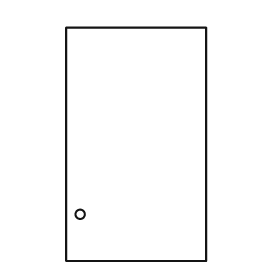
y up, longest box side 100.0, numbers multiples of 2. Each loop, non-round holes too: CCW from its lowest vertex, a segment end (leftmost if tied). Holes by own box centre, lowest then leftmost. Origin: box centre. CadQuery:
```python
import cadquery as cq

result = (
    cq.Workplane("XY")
    .moveTo(-30.0, -50.0)
    .lineTo(30.0, -50.0)
    .lineTo(30.0, 50.0)
    .lineTo(-30.0, 50.0)
    .close()
    .moveTo(-24.0, -30.0)
    .circle(2.0)
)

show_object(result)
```